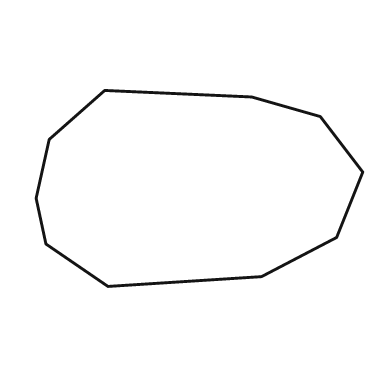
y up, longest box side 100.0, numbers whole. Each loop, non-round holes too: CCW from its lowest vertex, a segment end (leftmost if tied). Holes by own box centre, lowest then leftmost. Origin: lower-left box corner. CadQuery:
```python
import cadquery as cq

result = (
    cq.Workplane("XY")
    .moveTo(22.0, 0.0)
    .lineTo(69.0, 3.0)
    .lineTo(92.0, 15.0)
    .lineTo(100.0, 35.0)
    .lineTo(87.0, 52.0)
    .lineTo(66.0, 58.0)
    .lineTo(21.0, 60.0)
    .lineTo(4.0, 45.0)
    .lineTo(0.0, 27.0)
    .lineTo(3.0, 13.0)
    .close()
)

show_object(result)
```